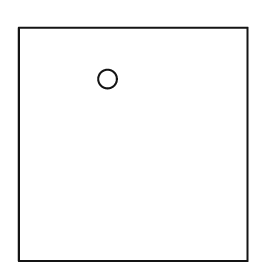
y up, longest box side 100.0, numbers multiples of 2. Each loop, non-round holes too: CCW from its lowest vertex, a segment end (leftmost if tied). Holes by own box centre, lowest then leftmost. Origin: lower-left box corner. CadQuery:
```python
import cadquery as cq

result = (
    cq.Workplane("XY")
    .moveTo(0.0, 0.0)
    .lineTo(98.0, 0.0)
    .lineTo(98.0, 100.0)
    .lineTo(0.0, 100.0)
    .close()
    .moveTo(38.0, 78.0)
    .circle(4.0)
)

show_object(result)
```